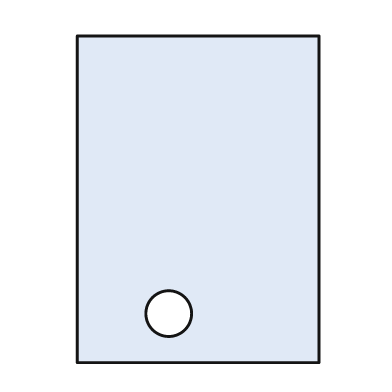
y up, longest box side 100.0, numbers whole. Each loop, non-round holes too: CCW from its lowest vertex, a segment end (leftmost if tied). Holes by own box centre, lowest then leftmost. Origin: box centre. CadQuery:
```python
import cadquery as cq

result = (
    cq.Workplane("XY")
    .moveTo(-37.0, -50.0)
    .lineTo(37.0, -50.0)
    .lineTo(37.0, 50.0)
    .lineTo(-37.0, 50.0)
    .close()
    .moveTo(-9.0, -35.0)
    .circle(7.0)
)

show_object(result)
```